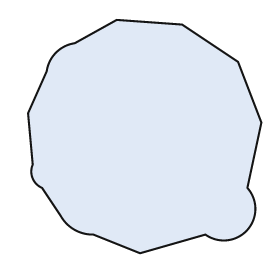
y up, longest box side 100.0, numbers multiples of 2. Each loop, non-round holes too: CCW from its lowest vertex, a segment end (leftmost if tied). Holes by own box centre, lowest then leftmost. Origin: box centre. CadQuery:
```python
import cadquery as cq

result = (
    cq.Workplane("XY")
    .moveTo(-2.0, -50.0)
    .lineTo(26.0, -42.0)
    .threePointArc((44.0, -40.0), (44.0, -22.0))
    .lineTo(50.0, 6.0)
    .lineTo(40.0, 32.0)
    .lineTo(16.0, 48.0)
    .lineTo(-12.0, 50.0)
    .lineTo(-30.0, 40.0)
    .threePointArc((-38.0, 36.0), (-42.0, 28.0))
    .lineTo(-50.0, 10.0)
    .lineTo(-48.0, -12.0)
    .threePointArc((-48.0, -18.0), (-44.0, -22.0))
    .lineTo(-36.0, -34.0)
    .threePointArc((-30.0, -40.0), (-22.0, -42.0))
    .close()
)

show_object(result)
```